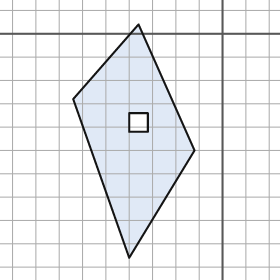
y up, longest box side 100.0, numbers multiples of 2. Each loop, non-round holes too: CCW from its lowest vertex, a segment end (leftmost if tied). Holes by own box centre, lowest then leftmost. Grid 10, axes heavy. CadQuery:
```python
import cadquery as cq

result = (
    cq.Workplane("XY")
    .moveTo(-40.0, -96.0)
    .lineTo(-12.0, -50.0)
    .lineTo(-36.0, 4.0)
    .lineTo(-64.0, -28.0)
    .close()
    .moveTo(-40.0, -42.0)
    .lineTo(-32.0, -42.0)
    .lineTo(-32.0, -34.0)
    .lineTo(-40.0, -34.0)
    .close()
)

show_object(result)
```